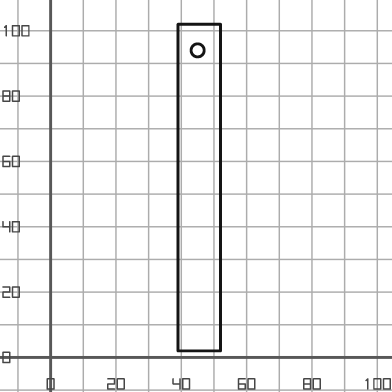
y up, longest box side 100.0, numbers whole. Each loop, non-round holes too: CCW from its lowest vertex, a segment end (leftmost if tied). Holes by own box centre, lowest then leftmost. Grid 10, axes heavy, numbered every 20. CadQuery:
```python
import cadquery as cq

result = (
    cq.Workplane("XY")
    .moveTo(39.0, 2.0)
    .lineTo(52.0, 2.0)
    .lineTo(52.0, 102.0)
    .lineTo(39.0, 102.0)
    .close()
    .moveTo(45.0, 94.0)
    .circle(2.0)
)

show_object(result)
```